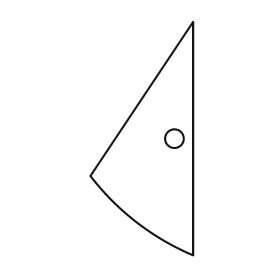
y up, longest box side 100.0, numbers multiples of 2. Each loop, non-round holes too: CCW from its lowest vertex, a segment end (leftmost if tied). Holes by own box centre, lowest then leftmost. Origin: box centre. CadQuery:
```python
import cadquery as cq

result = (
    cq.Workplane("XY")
    .moveTo(22.0, -50.0)
    .lineTo(22.0, 50.0)
    .lineTo(-22.0, -16.0)
    .threePointArc((-2.0, -36.0), (22.0, -50.0))
    .close()
    .moveTo(14.0, 0.0)
    .circle(4.0)
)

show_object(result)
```